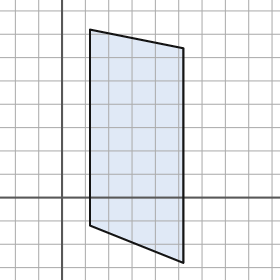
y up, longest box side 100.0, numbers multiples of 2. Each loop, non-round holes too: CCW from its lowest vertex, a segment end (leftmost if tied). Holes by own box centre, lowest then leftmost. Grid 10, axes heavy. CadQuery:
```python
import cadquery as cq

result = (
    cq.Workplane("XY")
    .moveTo(52.0, -28.0)
    .lineTo(52.0, 64.0)
    .lineTo(12.0, 72.0)
    .lineTo(12.0, -12.0)
    .close()
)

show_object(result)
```